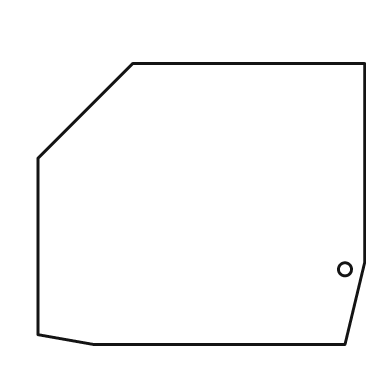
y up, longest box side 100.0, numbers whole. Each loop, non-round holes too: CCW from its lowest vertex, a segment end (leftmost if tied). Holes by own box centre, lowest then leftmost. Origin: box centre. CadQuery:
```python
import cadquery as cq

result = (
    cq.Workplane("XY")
    .moveTo(-33.0, -43.0)
    .lineTo(44.0, -43.0)
    .lineTo(50.0, -18.0)
    .lineTo(50.0, 43.0)
    .lineTo(-21.0, 43.0)
    .lineTo(-50.0, 14.0)
    .lineTo(-50.0, -40.0)
    .close()
    .moveTo(44.0, -20.0)
    .circle(2.0)
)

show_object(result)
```